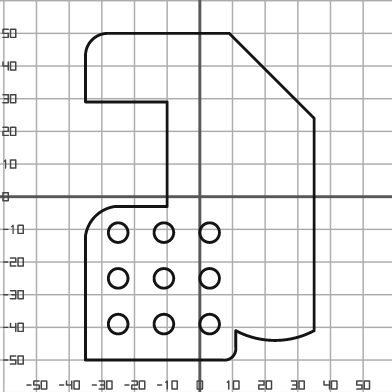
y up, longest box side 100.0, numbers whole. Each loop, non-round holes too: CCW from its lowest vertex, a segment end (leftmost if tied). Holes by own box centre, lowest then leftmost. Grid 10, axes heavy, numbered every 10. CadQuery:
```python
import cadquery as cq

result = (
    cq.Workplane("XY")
    .moveTo(-35.0, -50.0)
    .lineTo(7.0, -50.0)
    .threePointArc((10.0, -49.0), (11.0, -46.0))
    .lineTo(11.0, -41.0)
    .threePointArc((23.0, -44.0), (35.0, -41.0))
    .lineTo(35.0, 24.0)
    .lineTo(9.0, 50.0)
    .lineTo(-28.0, 50.0)
    .threePointArc((-33.0, 48.0), (-35.0, 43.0))
    .lineTo(-35.0, 29.0)
    .lineTo(-10.0, 29.0)
    .lineTo(-10.0, -3.0)
    .lineTo(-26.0, -3.0)
    .threePointArc((-32.0, -6.0), (-35.0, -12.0))
    .close()
    .moveTo(-25.0, -39.0)
    .circle(3.0)
    .moveTo(-11.0, -39.0)
    .circle(3.0)
    .moveTo(3.0, -39.0)
    .circle(3.0)
    .moveTo(-25.0, -25.0)
    .circle(3.0)
    .moveTo(-11.0, -25.0)
    .circle(3.0)
    .moveTo(3.0, -25.0)
    .circle(3.0)
    .moveTo(-25.0, -11.0)
    .circle(3.0)
    .moveTo(-11.0, -11.0)
    .circle(3.0)
    .moveTo(3.0, -11.0)
    .circle(3.0)
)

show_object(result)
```